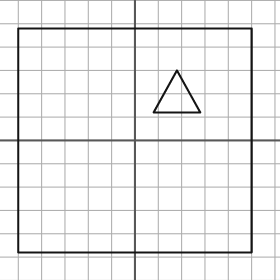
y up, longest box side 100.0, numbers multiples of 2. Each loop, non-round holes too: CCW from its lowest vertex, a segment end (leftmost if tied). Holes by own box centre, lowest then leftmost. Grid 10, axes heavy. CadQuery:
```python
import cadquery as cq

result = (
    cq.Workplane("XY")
    .moveTo(-50.0, -48.0)
    .lineTo(50.0, -48.0)
    .lineTo(50.0, 48.0)
    .lineTo(-50.0, 48.0)
    .close()
    .moveTo(8.0, 12.0)
    .lineTo(28.0, 12.0)
    .lineTo(18.0, 30.0)
    .close()
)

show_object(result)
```